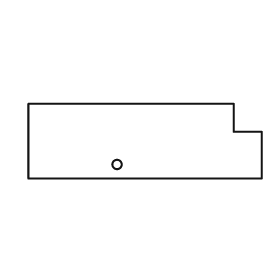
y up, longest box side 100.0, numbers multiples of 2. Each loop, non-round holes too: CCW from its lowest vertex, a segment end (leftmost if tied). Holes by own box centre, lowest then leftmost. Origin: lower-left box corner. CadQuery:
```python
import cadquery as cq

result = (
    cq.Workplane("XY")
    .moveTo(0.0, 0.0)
    .lineTo(100.0, 0.0)
    .lineTo(100.0, 20.0)
    .lineTo(88.0, 20.0)
    .lineTo(88.0, 32.0)
    .lineTo(0.0, 32.0)
    .close()
    .moveTo(38.0, 6.0)
    .circle(2.0)
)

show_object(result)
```